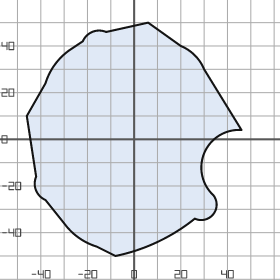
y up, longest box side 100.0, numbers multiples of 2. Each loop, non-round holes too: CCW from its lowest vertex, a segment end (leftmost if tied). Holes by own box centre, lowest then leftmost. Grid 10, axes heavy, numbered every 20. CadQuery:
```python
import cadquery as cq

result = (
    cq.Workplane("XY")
    .moveTo(-8.0, -50.0)
    .threePointArc((10.0, -44.0), (26.0, -34.0))
    .threePointArc((34.0, -32.0), (34.0, -24.0))
    .threePointArc((30.0, -6.0), (46.0, 4.0))
    .lineTo(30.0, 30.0)
    .threePointArc((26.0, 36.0), (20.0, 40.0))
    .lineTo(6.0, 50.0)
    .lineTo(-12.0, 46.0)
    .threePointArc((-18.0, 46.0), (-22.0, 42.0))
    .lineTo(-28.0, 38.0)
    .threePointArc((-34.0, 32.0), (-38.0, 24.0))
    .lineTo(-46.0, 10.0)
    .lineTo(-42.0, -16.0)
    .threePointArc((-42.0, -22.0), (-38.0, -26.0))
    .lineTo(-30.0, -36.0)
    .threePointArc((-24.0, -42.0), (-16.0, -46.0))
    .close()
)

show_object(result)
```